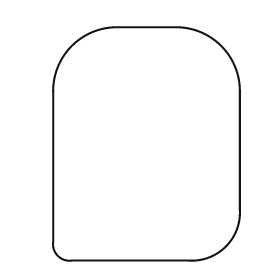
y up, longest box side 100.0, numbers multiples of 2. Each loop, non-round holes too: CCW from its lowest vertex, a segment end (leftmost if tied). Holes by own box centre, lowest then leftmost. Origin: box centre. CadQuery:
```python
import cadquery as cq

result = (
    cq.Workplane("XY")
    .moveTo(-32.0, -50.0)
    .lineTo(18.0, -50.0)
    .threePointArc((34.0, -44.0), (40.0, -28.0))
    .lineTo(40.0, 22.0)
    .threePointArc((32.0, 42.0), (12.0, 50.0))
    .lineTo(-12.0, 50.0)
    .threePointArc((-32.0, 42.0), (-40.0, 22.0))
    .lineTo(-40.0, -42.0)
    .threePointArc((-38.0, -48.0), (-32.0, -50.0))
    .close()
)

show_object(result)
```